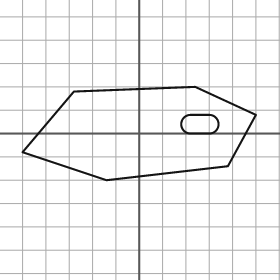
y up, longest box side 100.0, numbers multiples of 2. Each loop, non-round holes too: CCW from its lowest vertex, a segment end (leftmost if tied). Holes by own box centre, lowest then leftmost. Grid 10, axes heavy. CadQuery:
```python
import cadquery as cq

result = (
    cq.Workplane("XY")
    .moveTo(-14.0, -20.0)
    .lineTo(38.0, -14.0)
    .lineTo(50.0, 8.0)
    .lineTo(24.0, 20.0)
    .lineTo(-28.0, 18.0)
    .lineTo(-50.0, -8.0)
    .close()
    .moveTo(22.0, 0.0)
    .lineTo(30.0, 0.0)
    .threePointArc((34.0, 4.0), (30.0, 8.0))
    .lineTo(22.0, 8.0)
    .threePointArc((18.0, 4.0), (22.0, 0.0))
    .close()
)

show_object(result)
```